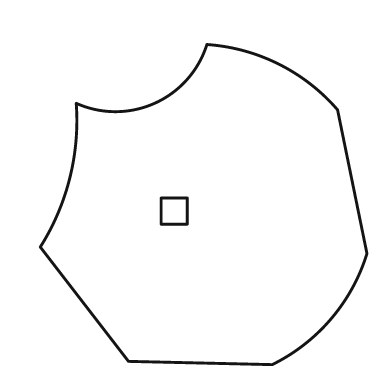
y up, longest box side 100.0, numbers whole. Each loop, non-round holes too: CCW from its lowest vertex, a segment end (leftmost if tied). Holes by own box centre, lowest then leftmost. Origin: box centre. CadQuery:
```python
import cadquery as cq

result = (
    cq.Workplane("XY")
    .moveTo(21.0, -49.0)
    .threePointArc((39.0, -35.0), (50.0, -15.0))
    .lineTo(41.0, 29.0)
    .threePointArc((23.0, 43.0), (1.0, 49.0))
    .threePointArc((-15.0, 31.0), (-39.0, 31.0))
    .threePointArc((-41.0, 8.0), (-50.0, -13.0))
    .lineTo(-23.0, -48.0)
    .close()
    .moveTo(-13.0, -6.0)
    .lineTo(-5.0, -6.0)
    .lineTo(-5.0, 2.0)
    .lineTo(-13.0, 2.0)
    .close()
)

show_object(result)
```